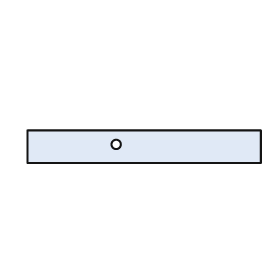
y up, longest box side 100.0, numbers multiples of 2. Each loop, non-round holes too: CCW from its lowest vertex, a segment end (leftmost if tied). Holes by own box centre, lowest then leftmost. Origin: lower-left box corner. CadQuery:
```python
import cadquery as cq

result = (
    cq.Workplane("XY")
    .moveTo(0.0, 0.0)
    .lineTo(100.0, 0.0)
    .lineTo(100.0, 14.0)
    .lineTo(0.0, 14.0)
    .close()
    .moveTo(38.0, 8.0)
    .circle(2.0)
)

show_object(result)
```